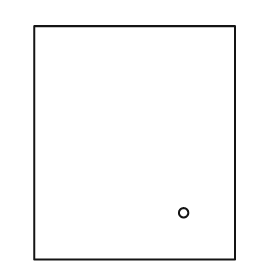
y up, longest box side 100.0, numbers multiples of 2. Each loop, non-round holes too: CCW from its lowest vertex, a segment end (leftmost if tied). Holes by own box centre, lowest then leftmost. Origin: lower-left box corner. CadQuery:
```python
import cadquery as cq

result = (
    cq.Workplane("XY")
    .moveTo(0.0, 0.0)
    .lineTo(86.0, 0.0)
    .lineTo(86.0, 100.0)
    .lineTo(0.0, 100.0)
    .close()
    .moveTo(64.0, 20.0)
    .circle(2.0)
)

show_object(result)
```